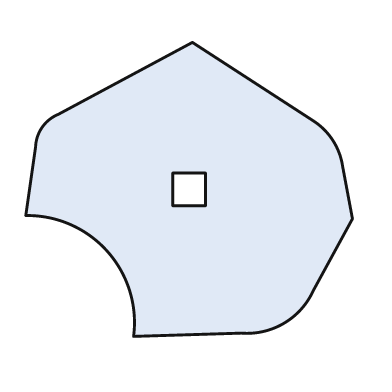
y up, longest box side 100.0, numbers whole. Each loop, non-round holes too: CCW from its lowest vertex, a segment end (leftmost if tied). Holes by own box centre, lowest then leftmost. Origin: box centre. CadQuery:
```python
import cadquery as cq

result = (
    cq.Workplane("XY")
    .moveTo(-17.0, -45.0)
    .lineTo(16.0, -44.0)
    .threePointArc((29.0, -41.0), (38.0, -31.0))
    .lineTo(50.0, -9.0)
    .lineTo(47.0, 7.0)
    .threePointArc((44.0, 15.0), (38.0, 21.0))
    .lineTo(1.0, 45.0)
    .lineTo(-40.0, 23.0)
    .threePointArc((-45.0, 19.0), (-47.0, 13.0))
    .lineTo(-50.0, -8.0)
    .threePointArc((-25.0, -19.0), (-17.0, -45.0))
    .close()
    .moveTo(-5.0, -5.0)
    .lineTo(5.0, -5.0)
    .lineTo(5.0, 5.0)
    .lineTo(-5.0, 5.0)
    .close()
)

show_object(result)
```